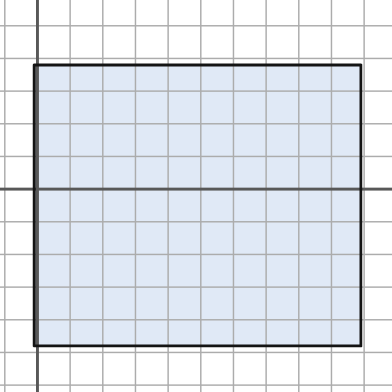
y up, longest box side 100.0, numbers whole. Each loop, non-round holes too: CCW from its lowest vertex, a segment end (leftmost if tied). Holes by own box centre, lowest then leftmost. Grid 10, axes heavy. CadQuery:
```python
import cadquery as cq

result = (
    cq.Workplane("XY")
    .moveTo(-1.0, -48.0)
    .lineTo(99.0, -48.0)
    .lineTo(99.0, 38.0)
    .lineTo(-1.0, 38.0)
    .close()
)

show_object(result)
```